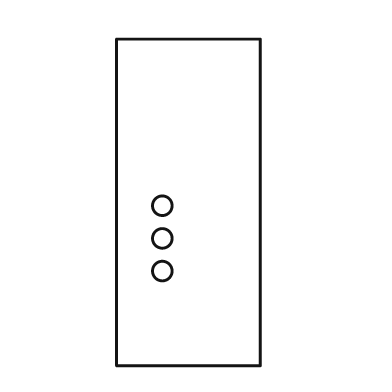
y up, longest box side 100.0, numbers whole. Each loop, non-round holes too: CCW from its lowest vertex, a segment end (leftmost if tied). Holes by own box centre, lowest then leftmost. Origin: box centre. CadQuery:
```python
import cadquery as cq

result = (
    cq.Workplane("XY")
    .moveTo(-22.0, -50.0)
    .lineTo(22.0, -50.0)
    .lineTo(22.0, 50.0)
    .lineTo(-22.0, 50.0)
    .close()
    .moveTo(-8.0, -21.0)
    .circle(3.0)
    .moveTo(-8.0, -11.0)
    .circle(3.0)
    .moveTo(-8.0, -1.0)
    .circle(3.0)
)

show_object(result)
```